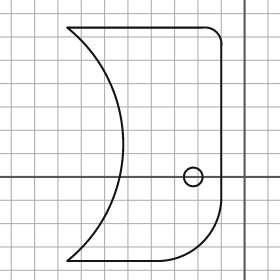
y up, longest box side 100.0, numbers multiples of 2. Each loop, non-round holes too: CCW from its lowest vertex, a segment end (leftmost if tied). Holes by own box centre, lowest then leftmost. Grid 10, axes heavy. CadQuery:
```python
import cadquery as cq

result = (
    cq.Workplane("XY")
    .moveTo(-76.0, -36.0)
    .lineTo(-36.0, -36.0)
    .threePointArc((-18.0, -28.0), (-10.0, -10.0))
    .lineTo(-10.0, 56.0)
    .threePointArc((-12.0, 62.0), (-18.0, 64.0))
    .lineTo(-76.0, 64.0)
    .threePointArc((-52.0, 14.0), (-76.0, -36.0))
    .close()
    .moveTo(-22.0, 0.0)
    .circle(4.0)
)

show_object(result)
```